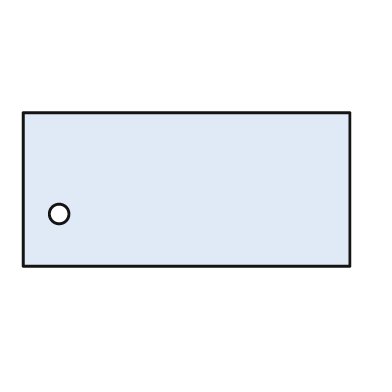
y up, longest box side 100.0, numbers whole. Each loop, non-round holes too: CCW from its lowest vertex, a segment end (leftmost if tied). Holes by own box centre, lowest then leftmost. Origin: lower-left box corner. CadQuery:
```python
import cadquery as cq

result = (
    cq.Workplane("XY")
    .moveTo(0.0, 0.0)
    .lineTo(100.0, 0.0)
    .lineTo(100.0, 47.0)
    .lineTo(0.0, 47.0)
    .close()
    .moveTo(11.0, 16.0)
    .circle(3.0)
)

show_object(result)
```